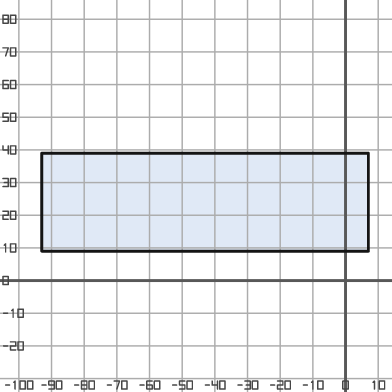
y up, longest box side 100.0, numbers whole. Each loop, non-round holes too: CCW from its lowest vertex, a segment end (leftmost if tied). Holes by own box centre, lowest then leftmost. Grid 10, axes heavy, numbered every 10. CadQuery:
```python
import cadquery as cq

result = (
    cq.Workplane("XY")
    .moveTo(-93.0, 9.0)
    .lineTo(7.0, 9.0)
    .lineTo(7.0, 39.0)
    .lineTo(-93.0, 39.0)
    .close()
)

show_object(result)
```